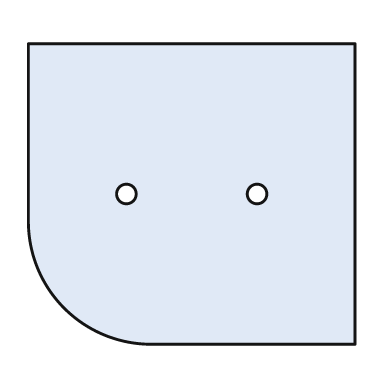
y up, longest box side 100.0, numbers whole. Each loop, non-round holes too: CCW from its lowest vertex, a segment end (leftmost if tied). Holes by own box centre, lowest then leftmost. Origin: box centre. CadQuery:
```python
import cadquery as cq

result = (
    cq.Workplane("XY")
    .moveTo(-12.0, -46.0)
    .lineTo(50.0, -46.0)
    .lineTo(50.0, 46.0)
    .lineTo(-50.0, 46.0)
    .lineTo(-50.0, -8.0)
    .threePointArc((-39.0, -35.0), (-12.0, -46.0))
    .close()
    .moveTo(-20.0, 0.0)
    .circle(3.0)
    .moveTo(20.0, 0.0)
    .circle(3.0)
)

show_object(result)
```